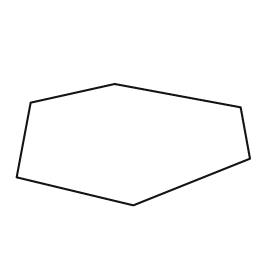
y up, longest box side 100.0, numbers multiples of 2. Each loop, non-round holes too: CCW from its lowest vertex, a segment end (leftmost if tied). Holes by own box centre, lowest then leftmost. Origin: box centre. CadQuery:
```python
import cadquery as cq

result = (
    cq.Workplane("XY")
    .moveTo(0.0, -26.0)
    .lineTo(50.0, -6.0)
    .lineTo(46.0, 16.0)
    .lineTo(-8.0, 26.0)
    .lineTo(-44.0, 18.0)
    .lineTo(-50.0, -14.0)
    .close()
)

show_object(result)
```